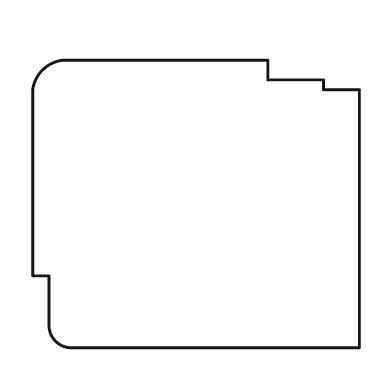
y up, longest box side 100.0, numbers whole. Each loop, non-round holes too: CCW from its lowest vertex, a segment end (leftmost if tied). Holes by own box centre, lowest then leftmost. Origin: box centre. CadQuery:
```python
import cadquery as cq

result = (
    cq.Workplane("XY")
    .moveTo(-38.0, -44.0)
    .lineTo(50.0, -44.0)
    .lineTo(50.0, 35.0)
    .lineTo(39.0, 35.0)
    .lineTo(39.0, 38.0)
    .lineTo(22.0, 38.0)
    .lineTo(22.0, 44.0)
    .lineTo(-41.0, 44.0)
    .threePointArc((-47.0, 41.0), (-50.0, 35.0))
    .lineTo(-50.0, -22.0)
    .lineTo(-45.0, -22.0)
    .lineTo(-45.0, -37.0)
    .threePointArc((-43.0, -42.0), (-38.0, -44.0))
    .close()
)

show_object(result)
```